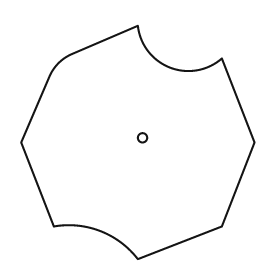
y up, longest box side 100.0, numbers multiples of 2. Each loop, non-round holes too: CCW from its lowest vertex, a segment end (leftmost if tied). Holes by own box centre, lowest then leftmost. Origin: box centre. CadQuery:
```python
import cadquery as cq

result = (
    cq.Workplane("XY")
    .moveTo(0.0, -50.0)
    .lineTo(36.0, -36.0)
    .lineTo(50.0, 0.0)
    .lineTo(36.0, 36.0)
    .threePointArc((14.0, 32.0), (0.0, 50.0))
    .lineTo(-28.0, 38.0)
    .threePointArc((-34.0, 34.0), (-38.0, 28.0))
    .lineTo(-50.0, 0.0)
    .lineTo(-36.0, -36.0)
    .threePointArc((-16.0, -38.0), (0.0, -50.0))
    .close()
    .moveTo(2.0, 2.0)
    .circle(2.0)
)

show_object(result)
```